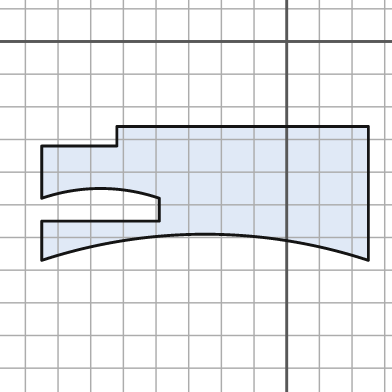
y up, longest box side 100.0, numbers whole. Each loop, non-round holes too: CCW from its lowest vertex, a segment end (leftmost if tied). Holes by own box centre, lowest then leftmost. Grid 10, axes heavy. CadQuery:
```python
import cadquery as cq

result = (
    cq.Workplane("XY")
    .moveTo(-75.0, -67.0)
    .threePointArc((-25.0, -59.0), (25.0, -67.0))
    .lineTo(25.0, -26.0)
    .lineTo(-52.0, -26.0)
    .lineTo(-52.0, -32.0)
    .lineTo(-75.0, -32.0)
    .lineTo(-75.0, -48.0)
    .threePointArc((-57.0, -45.0), (-39.0, -48.0))
    .lineTo(-39.0, -55.0)
    .lineTo(-75.0, -55.0)
    .close()
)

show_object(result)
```